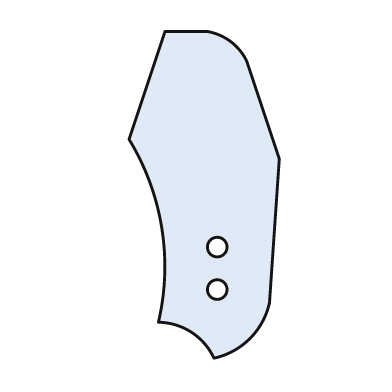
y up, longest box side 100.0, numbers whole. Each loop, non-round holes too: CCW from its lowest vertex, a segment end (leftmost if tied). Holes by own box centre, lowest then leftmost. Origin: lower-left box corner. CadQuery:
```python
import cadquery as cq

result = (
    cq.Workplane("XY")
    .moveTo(26.0, 0.0)
    .threePointArc((37.0, 6.0), (43.0, 17.0))
    .lineTo(46.0, 61.0)
    .lineTo(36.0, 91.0)
    .threePointArc((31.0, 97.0), (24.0, 100.0))
    .lineTo(11.0, 100.0)
    .lineTo(0.0, 67.0)
    .threePointArc((10.0, 40.0), (9.0, 11.0))
    .threePointArc((19.0, 8.0), (26.0, 0.0))
    .close()
    .moveTo(27.0, 21.0)
    .circle(3.0)
    .moveTo(27.0, 34.0)
    .circle(3.0)
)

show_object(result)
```